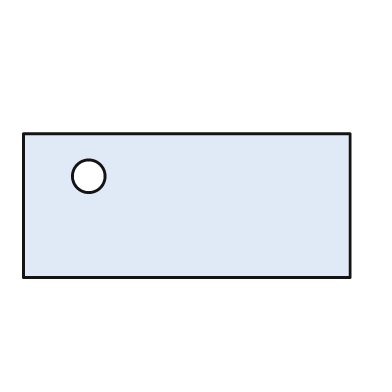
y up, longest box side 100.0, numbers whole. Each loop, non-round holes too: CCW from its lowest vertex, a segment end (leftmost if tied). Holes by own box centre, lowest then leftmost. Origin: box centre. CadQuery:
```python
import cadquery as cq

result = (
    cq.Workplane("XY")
    .moveTo(-50.0, -22.0)
    .lineTo(50.0, -22.0)
    .lineTo(50.0, 22.0)
    .lineTo(-50.0, 22.0)
    .close()
    .moveTo(-30.0, 9.0)
    .circle(5.0)
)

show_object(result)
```